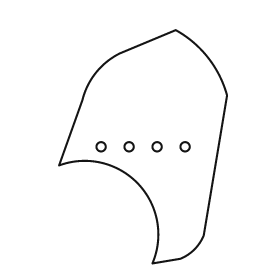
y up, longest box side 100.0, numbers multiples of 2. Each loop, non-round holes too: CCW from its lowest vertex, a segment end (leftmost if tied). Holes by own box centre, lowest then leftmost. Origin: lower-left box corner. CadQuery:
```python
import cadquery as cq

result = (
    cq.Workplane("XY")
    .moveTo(40.0, 0.0)
    .lineTo(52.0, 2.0)
    .threePointArc((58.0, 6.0), (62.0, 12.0))
    .lineTo(72.0, 72.0)
    .threePointArc((64.0, 88.0), (50.0, 100.0))
    .lineTo(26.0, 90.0)
    .threePointArc((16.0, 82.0), (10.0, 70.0))
    .lineTo(0.0, 42.0)
    .threePointArc((34.0, 34.0), (40.0, 0.0))
    .close()
    .moveTo(18.0, 50.0)
    .circle(2.0)
    .moveTo(30.0, 50.0)
    .circle(2.0)
    .moveTo(42.0, 50.0)
    .circle(2.0)
    .moveTo(54.0, 50.0)
    .circle(2.0)
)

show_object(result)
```